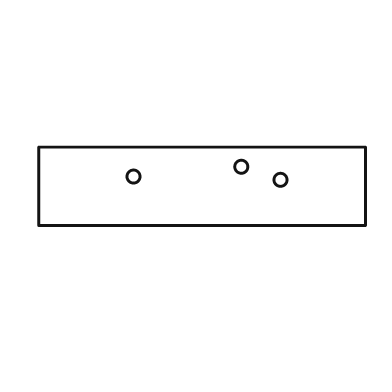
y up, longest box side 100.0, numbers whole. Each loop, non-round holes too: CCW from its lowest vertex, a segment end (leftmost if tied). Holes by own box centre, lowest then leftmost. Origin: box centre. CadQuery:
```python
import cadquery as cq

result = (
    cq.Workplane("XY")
    .moveTo(-50.0, -12.0)
    .lineTo(50.0, -12.0)
    .lineTo(50.0, 12.0)
    .lineTo(-50.0, 12.0)
    .close()
    .moveTo(24.0, 2.0)
    .circle(2.0)
    .moveTo(-21.0, 3.0)
    .circle(2.0)
    .moveTo(12.0, 6.0)
    .circle(2.0)
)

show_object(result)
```